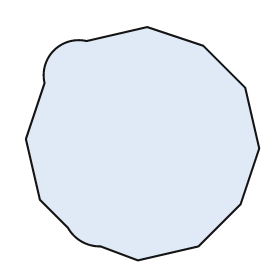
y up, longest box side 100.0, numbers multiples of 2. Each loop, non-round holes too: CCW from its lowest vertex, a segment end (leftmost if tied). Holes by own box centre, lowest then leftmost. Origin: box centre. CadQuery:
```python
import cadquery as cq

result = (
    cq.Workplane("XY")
    .moveTo(-2.0, -50.0)
    .lineTo(24.0, -44.0)
    .lineTo(42.0, -26.0)
    .lineTo(50.0, -2.0)
    .lineTo(44.0, 24.0)
    .lineTo(26.0, 42.0)
    .lineTo(2.0, 50.0)
    .lineTo(-24.0, 44.0)
    .threePointArc((-38.0, 40.0), (-42.0, 26.0))
    .lineTo(-50.0, 2.0)
    .lineTo(-44.0, -24.0)
    .lineTo(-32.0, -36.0)
    .threePointArc((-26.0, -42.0), (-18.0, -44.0))
    .close()
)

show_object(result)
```